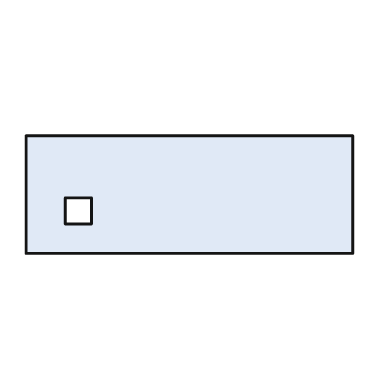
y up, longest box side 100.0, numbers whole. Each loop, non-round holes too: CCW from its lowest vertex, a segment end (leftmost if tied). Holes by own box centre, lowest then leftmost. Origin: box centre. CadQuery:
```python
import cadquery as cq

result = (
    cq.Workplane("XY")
    .moveTo(-50.0, -18.0)
    .lineTo(50.0, -18.0)
    .lineTo(50.0, 18.0)
    .lineTo(-50.0, 18.0)
    .close()
    .moveTo(-38.0, -9.0)
    .lineTo(-30.0, -9.0)
    .lineTo(-30.0, -1.0)
    .lineTo(-38.0, -1.0)
    .close()
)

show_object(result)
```